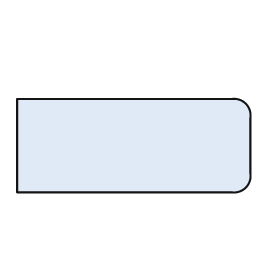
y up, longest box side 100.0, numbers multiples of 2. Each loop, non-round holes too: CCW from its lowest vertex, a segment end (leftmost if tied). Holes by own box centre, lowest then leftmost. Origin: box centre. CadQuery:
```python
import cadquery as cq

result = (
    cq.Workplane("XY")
    .moveTo(-50.0, -20.0)
    .lineTo(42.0, -20.0)
    .threePointArc((48.0, -18.0), (50.0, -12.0))
    .lineTo(50.0, 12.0)
    .threePointArc((48.0, 18.0), (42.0, 20.0))
    .lineTo(-50.0, 20.0)
    .close()
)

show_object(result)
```